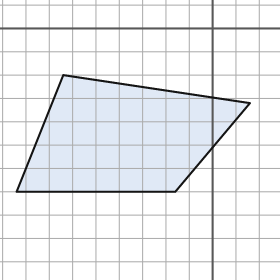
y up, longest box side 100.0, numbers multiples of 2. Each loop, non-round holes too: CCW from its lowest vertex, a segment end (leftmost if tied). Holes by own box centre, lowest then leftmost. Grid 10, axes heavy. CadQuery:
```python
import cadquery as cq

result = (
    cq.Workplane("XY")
    .moveTo(-84.0, -70.0)
    .lineTo(-16.0, -70.0)
    .lineTo(16.0, -32.0)
    .lineTo(-64.0, -20.0)
    .close()
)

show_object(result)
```